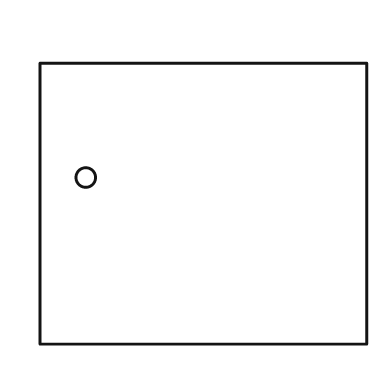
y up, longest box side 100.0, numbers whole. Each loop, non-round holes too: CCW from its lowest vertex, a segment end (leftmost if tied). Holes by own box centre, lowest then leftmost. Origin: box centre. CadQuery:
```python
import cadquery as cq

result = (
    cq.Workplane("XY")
    .moveTo(-50.0, -43.0)
    .lineTo(50.0, -43.0)
    .lineTo(50.0, 43.0)
    .lineTo(-50.0, 43.0)
    .close()
    .moveTo(-36.0, 8.0)
    .circle(3.0)
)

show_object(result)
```